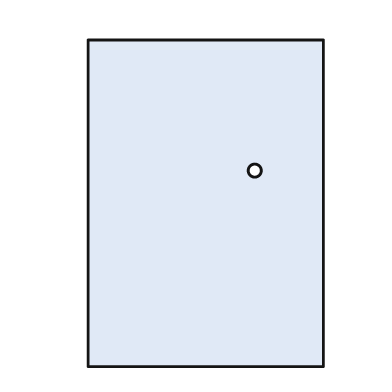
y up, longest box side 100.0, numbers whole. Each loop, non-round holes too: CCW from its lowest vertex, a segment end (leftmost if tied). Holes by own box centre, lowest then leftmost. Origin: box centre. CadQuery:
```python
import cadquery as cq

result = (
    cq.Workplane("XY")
    .moveTo(-36.0, -50.0)
    .lineTo(36.0, -50.0)
    .lineTo(36.0, 50.0)
    .lineTo(-36.0, 50.0)
    .close()
    .moveTo(15.0, 10.0)
    .circle(2.0)
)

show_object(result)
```